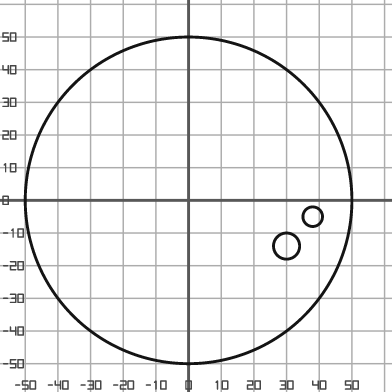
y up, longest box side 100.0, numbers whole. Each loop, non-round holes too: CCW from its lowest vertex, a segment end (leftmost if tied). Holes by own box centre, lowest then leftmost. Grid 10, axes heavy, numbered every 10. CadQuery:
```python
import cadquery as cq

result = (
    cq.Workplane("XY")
    .moveTo(0.0, 0.0)
    .circle(50.0)
    .moveTo(30.0, -14.0)
    .circle(4.0)
    .moveTo(38.0, -5.0)
    .circle(3.0)
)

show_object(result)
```